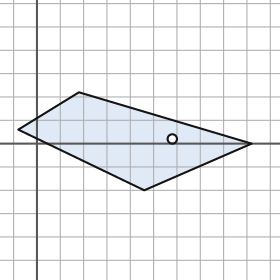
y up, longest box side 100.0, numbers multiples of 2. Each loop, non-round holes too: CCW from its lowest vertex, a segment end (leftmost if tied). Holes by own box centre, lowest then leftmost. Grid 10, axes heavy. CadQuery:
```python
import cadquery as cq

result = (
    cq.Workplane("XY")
    .moveTo(46.0, -20.0)
    .lineTo(92.0, 0.0)
    .lineTo(18.0, 22.0)
    .lineTo(-8.0, 6.0)
    .close()
    .moveTo(58.0, 2.0)
    .circle(2.0)
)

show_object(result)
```